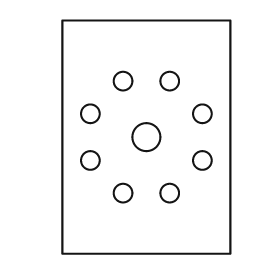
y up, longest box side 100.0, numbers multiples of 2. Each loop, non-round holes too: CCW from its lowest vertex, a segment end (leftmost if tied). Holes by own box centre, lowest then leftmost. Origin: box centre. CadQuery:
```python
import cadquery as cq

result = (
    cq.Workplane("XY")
    .moveTo(-36.0, -50.0)
    .lineTo(36.0, -50.0)
    .lineTo(36.0, 50.0)
    .lineTo(-36.0, 50.0)
    .close()
    .moveTo(-10.0, -24.0)
    .circle(4.0)
    .moveTo(10.0, -24.0)
    .circle(4.0)
    .moveTo(-24.0, -10.0)
    .circle(4.0)
    .moveTo(24.0, -10.0)
    .circle(4.0)
    .moveTo(0.0, 0.0)
    .circle(6.0)
    .moveTo(-24.0, 10.0)
    .circle(4.0)
    .moveTo(24.0, 10.0)
    .circle(4.0)
    .moveTo(-10.0, 24.0)
    .circle(4.0)
    .moveTo(10.0, 24.0)
    .circle(4.0)
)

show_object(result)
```